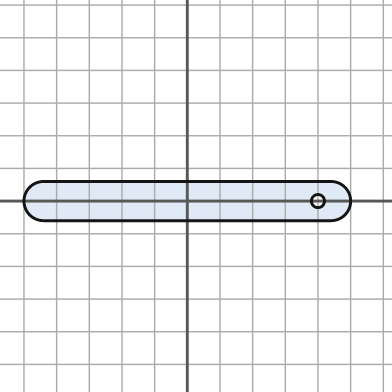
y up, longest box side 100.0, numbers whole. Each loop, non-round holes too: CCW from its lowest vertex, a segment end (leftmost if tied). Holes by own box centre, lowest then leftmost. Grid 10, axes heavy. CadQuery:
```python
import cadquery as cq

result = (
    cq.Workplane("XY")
    .moveTo(-44.0, -6.0)
    .lineTo(44.0, -6.0)
    .threePointArc((50.0, 0.0), (44.0, 6.0))
    .lineTo(-44.0, 6.0)
    .threePointArc((-50.0, 0.0), (-44.0, -6.0))
    .close()
    .moveTo(40.0, 0.0)
    .circle(2.0)
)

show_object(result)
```